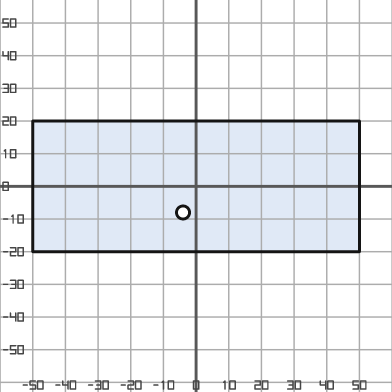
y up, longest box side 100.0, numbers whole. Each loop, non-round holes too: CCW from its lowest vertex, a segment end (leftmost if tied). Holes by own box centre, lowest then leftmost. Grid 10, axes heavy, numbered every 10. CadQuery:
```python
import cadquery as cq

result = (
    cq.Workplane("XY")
    .moveTo(-50.0, -20.0)
    .lineTo(50.0, -20.0)
    .lineTo(50.0, 20.0)
    .lineTo(-50.0, 20.0)
    .close()
    .moveTo(-4.0, -8.0)
    .circle(2.0)
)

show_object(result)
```